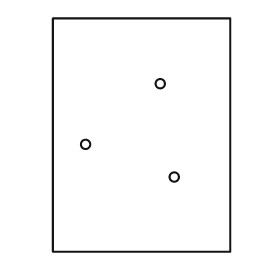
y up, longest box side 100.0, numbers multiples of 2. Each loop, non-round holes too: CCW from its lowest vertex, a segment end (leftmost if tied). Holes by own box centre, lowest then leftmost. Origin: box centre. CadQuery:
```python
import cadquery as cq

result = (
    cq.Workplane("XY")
    .moveTo(-38.0, -50.0)
    .lineTo(38.0, -50.0)
    .lineTo(38.0, 50.0)
    .lineTo(-38.0, 50.0)
    .close()
    .moveTo(14.0, -18.0)
    .circle(2.0)
    .moveTo(-24.0, -4.0)
    .circle(2.0)
    .moveTo(8.0, 22.0)
    .circle(2.0)
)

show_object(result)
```